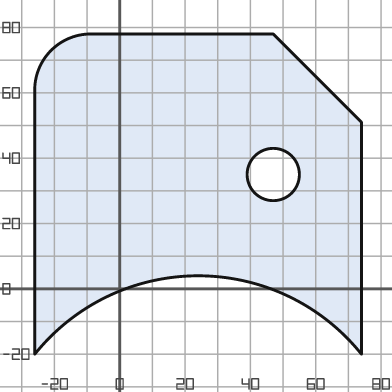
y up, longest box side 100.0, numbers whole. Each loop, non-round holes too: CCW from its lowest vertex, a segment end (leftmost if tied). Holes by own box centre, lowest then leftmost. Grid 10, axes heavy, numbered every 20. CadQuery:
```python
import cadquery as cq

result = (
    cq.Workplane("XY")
    .moveTo(-26.0, -20.0)
    .threePointArc((24.0, 4.0), (74.0, -20.0))
    .lineTo(74.0, 51.0)
    .lineTo(47.0, 78.0)
    .lineTo(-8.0, 78.0)
    .threePointArc((-21.0, 73.0), (-26.0, 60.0))
    .close()
    .moveTo(47.0, 35.0)
    .circle(8.0)
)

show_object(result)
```